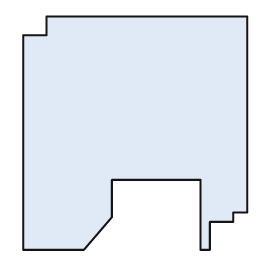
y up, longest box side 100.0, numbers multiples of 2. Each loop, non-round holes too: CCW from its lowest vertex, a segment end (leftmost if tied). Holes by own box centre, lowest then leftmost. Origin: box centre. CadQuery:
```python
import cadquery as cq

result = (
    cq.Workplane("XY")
    .moveTo(-48.0, -50.0)
    .lineTo(-22.0, -50.0)
    .lineTo(-10.0, -36.0)
    .lineTo(-10.0, -20.0)
    .lineTo(28.0, -20.0)
    .lineTo(28.0, -50.0)
    .lineTo(32.0, -50.0)
    .lineTo(32.0, -38.0)
    .lineTo(42.0, -38.0)
    .lineTo(42.0, -34.0)
    .lineTo(48.0, -34.0)
    .lineTo(48.0, 50.0)
    .lineTo(-38.0, 50.0)
    .lineTo(-38.0, 42.0)
    .lineTo(-48.0, 42.0)
    .close()
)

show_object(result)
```